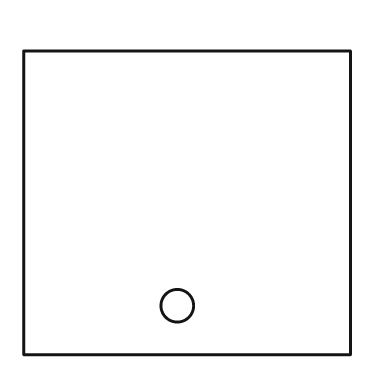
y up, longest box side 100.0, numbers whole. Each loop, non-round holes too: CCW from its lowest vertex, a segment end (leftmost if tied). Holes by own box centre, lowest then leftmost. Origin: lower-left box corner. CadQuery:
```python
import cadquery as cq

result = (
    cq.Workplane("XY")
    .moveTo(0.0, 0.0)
    .lineTo(100.0, 0.0)
    .lineTo(100.0, 93.0)
    .lineTo(0.0, 93.0)
    .close()
    .moveTo(47.0, 15.0)
    .circle(5.0)
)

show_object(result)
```